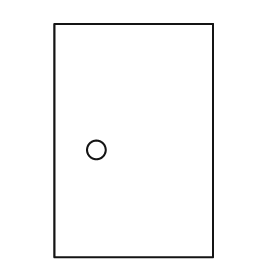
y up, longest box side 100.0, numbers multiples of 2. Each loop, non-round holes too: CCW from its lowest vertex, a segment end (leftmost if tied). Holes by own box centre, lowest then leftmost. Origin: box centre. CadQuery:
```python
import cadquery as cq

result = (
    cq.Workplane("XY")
    .moveTo(-34.0, -50.0)
    .lineTo(34.0, -50.0)
    .lineTo(34.0, 50.0)
    .lineTo(-34.0, 50.0)
    .close()
    .moveTo(-16.0, -4.0)
    .circle(4.0)
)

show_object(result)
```